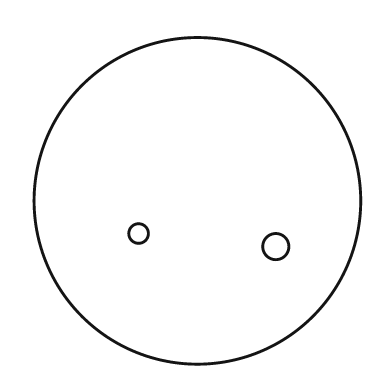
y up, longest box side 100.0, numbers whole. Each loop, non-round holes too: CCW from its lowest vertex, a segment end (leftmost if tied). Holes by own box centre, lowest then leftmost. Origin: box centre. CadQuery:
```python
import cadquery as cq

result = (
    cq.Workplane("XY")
    .moveTo(0.0, 0.0)
    .circle(50.0)
    .moveTo(24.0, -14.0)
    .circle(4.0)
    .moveTo(-18.0, -10.0)
    .circle(3.0)
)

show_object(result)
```